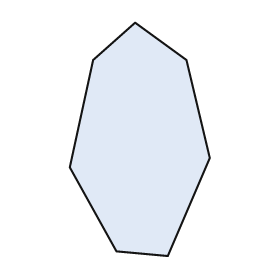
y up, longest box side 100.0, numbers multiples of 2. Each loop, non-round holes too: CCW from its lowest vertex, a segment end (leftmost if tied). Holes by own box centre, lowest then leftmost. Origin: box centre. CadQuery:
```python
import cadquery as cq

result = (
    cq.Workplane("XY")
    .moveTo(12.0, -50.0)
    .lineTo(30.0, -8.0)
    .lineTo(20.0, 34.0)
    .lineTo(-2.0, 50.0)
    .lineTo(-20.0, 34.0)
    .lineTo(-30.0, -12.0)
    .lineTo(-10.0, -48.0)
    .close()
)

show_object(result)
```